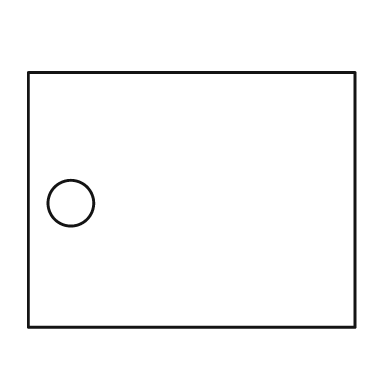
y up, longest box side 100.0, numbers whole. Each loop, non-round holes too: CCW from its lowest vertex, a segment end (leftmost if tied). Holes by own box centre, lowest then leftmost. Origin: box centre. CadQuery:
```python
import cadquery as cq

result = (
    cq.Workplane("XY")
    .moveTo(-50.0, -39.0)
    .lineTo(50.0, -39.0)
    .lineTo(50.0, 39.0)
    .lineTo(-50.0, 39.0)
    .close()
    .moveTo(-37.0, -1.0)
    .circle(7.0)
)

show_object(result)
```